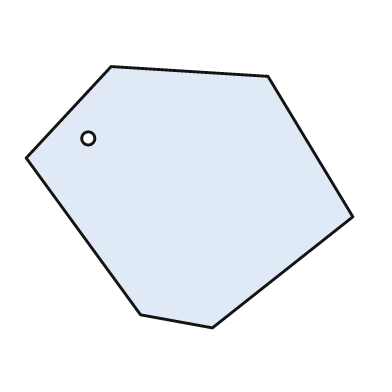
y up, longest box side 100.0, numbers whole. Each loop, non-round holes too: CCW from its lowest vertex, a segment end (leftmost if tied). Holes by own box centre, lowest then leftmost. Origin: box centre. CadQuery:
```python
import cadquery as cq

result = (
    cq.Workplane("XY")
    .moveTo(7.0, -40.0)
    .lineTo(50.0, -6.0)
    .lineTo(24.0, 37.0)
    .lineTo(-24.0, 40.0)
    .lineTo(-50.0, 12.0)
    .lineTo(-15.0, -36.0)
    .close()
    .moveTo(-31.0, 18.0)
    .circle(2.0)
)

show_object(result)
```